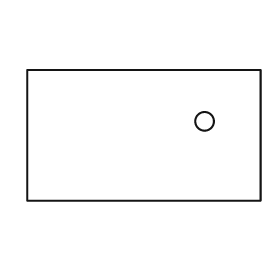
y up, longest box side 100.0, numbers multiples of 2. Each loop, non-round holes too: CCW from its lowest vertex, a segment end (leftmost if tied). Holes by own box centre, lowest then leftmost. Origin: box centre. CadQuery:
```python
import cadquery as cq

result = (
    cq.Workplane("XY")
    .moveTo(-50.0, -28.0)
    .lineTo(50.0, -28.0)
    .lineTo(50.0, 28.0)
    .lineTo(-50.0, 28.0)
    .close()
    .moveTo(26.0, 6.0)
    .circle(4.0)
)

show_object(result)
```